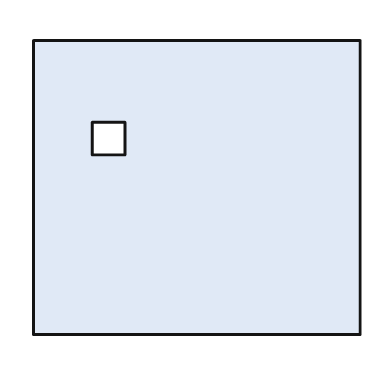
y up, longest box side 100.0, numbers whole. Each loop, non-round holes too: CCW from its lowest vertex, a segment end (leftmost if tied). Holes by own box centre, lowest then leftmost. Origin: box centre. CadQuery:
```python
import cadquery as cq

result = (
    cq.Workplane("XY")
    .moveTo(-50.0, -45.0)
    .lineTo(50.0, -45.0)
    .lineTo(50.0, 45.0)
    .lineTo(-50.0, 45.0)
    .close()
    .moveTo(-32.0, 10.0)
    .lineTo(-22.0, 10.0)
    .lineTo(-22.0, 20.0)
    .lineTo(-32.0, 20.0)
    .close()
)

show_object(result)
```